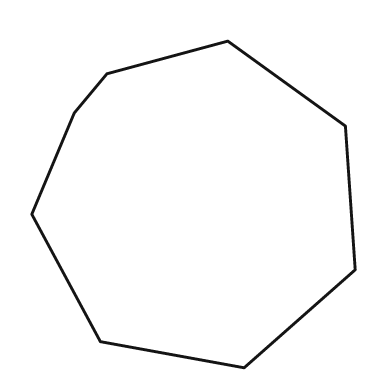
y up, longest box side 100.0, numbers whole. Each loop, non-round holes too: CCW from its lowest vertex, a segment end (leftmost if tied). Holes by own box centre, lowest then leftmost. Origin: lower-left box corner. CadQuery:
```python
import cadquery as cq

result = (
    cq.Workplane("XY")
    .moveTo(65.0, 0.0)
    .lineTo(99.0, 30.0)
    .lineTo(96.0, 74.0)
    .lineTo(60.0, 100.0)
    .lineTo(23.0, 90.0)
    .lineTo(13.0, 78.0)
    .lineTo(0.0, 47.0)
    .lineTo(21.0, 8.0)
    .close()
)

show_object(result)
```